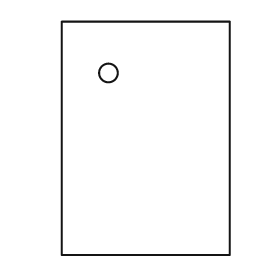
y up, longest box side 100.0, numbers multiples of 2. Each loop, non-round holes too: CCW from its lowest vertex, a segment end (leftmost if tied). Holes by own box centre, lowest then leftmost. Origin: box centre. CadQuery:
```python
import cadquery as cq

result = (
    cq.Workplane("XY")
    .moveTo(-36.0, -50.0)
    .lineTo(36.0, -50.0)
    .lineTo(36.0, 50.0)
    .lineTo(-36.0, 50.0)
    .close()
    .moveTo(-16.0, 28.0)
    .circle(4.0)
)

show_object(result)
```